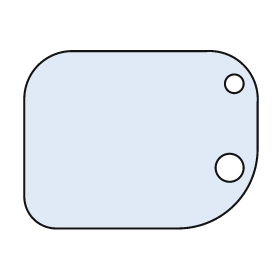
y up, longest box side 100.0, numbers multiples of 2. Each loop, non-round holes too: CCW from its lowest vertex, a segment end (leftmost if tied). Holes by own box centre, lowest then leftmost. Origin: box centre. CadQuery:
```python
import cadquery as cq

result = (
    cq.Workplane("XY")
    .moveTo(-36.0, -38.0)
    .lineTo(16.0, -38.0)
    .threePointArc((40.0, -28.0), (50.0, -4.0))
    .lineTo(50.0, 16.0)
    .threePointArc((44.0, 32.0), (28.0, 38.0))
    .lineTo(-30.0, 38.0)
    .threePointArc((-44.0, 32.0), (-50.0, 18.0))
    .lineTo(-50.0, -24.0)
    .threePointArc((-46.0, -34.0), (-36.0, -38.0))
    .close()
    .moveTo(38.0, -12.0)
    .circle(6.0)
    .moveTo(40.0, 24.0)
    .circle(4.0)
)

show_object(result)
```